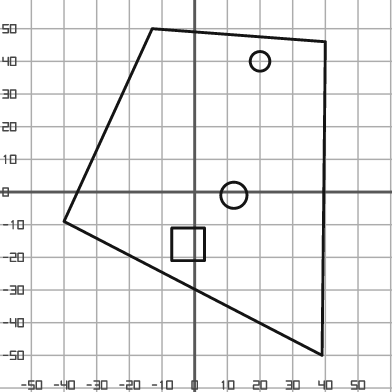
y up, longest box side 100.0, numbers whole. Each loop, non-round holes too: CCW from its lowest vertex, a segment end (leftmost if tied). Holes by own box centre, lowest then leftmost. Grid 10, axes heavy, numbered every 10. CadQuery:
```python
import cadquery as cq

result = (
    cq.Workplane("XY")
    .moveTo(39.0, -50.0)
    .lineTo(40.0, 46.0)
    .lineTo(-13.0, 50.0)
    .lineTo(-40.0, -9.0)
    .close()
    .moveTo(-7.0, -21.0)
    .lineTo(3.0, -21.0)
    .lineTo(3.0, -11.0)
    .lineTo(-7.0, -11.0)
    .close()
    .moveTo(12.0, -1.0)
    .circle(4.0)
    .moveTo(20.0, 40.0)
    .circle(3.0)
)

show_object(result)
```